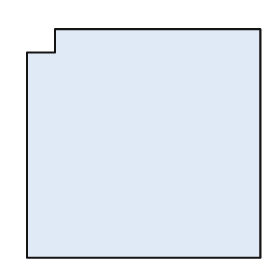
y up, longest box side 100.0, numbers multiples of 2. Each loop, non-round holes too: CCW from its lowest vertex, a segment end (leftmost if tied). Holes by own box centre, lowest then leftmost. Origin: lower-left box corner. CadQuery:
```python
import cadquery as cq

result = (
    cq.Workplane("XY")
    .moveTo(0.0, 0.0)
    .lineTo(100.0, 0.0)
    .lineTo(100.0, 98.0)
    .lineTo(12.0, 98.0)
    .lineTo(12.0, 88.0)
    .lineTo(0.0, 88.0)
    .close()
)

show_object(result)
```